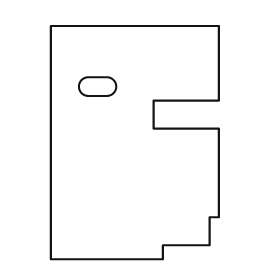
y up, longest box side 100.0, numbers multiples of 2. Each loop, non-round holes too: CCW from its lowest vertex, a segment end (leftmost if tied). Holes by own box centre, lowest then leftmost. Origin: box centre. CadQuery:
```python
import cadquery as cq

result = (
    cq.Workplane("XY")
    .moveTo(-36.0, -50.0)
    .lineTo(12.0, -50.0)
    .lineTo(12.0, -44.0)
    .lineTo(32.0, -44.0)
    .lineTo(32.0, -32.0)
    .lineTo(36.0, -32.0)
    .lineTo(36.0, 6.0)
    .lineTo(8.0, 6.0)
    .lineTo(8.0, 18.0)
    .lineTo(36.0, 18.0)
    .lineTo(36.0, 50.0)
    .lineTo(-36.0, 50.0)
    .close()
    .moveTo(-20.0, 20.0)
    .lineTo(-12.0, 20.0)
    .threePointArc((-8.0, 24.0), (-12.0, 28.0))
    .lineTo(-20.0, 28.0)
    .threePointArc((-24.0, 24.0), (-20.0, 20.0))
    .close()
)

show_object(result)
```